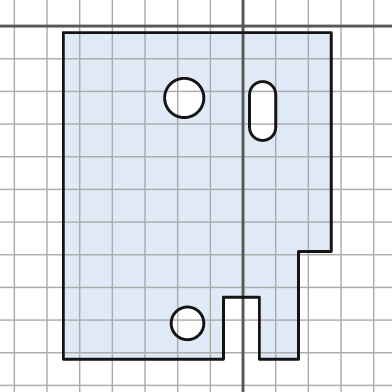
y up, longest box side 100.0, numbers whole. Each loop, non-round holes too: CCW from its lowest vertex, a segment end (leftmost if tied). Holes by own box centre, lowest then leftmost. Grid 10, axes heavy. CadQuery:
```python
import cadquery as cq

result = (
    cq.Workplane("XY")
    .moveTo(-55.0, -102.0)
    .lineTo(-6.0, -102.0)
    .lineTo(-6.0, -83.0)
    .lineTo(5.0, -83.0)
    .lineTo(5.0, -102.0)
    .lineTo(17.0, -102.0)
    .lineTo(17.0, -69.0)
    .lineTo(27.0, -69.0)
    .lineTo(27.0, -2.0)
    .lineTo(-55.0, -2.0)
    .close()
    .moveTo(-17.0, -91.0)
    .circle(5.0)
    .moveTo(2.0, -31.0)
    .threePointArc((6.0, -35.0), (10.0, -31.0))
    .lineTo(10.0, -21.0)
    .threePointArc((6.0, -17.0), (2.0, -21.0))
    .close()
    .moveTo(-18.0, -22.0)
    .circle(6.0)
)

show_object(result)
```